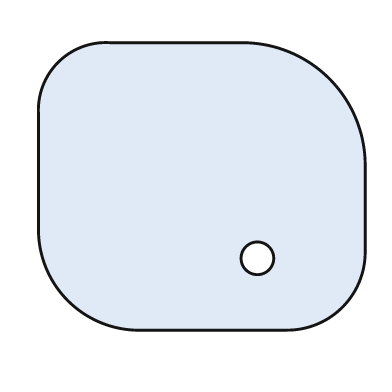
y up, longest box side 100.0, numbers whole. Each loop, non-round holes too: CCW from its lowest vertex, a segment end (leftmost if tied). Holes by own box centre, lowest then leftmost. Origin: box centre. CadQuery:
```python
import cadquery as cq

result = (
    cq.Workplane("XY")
    .moveTo(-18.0, -44.0)
    .lineTo(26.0, -44.0)
    .threePointArc((43.0, -37.0), (50.0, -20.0))
    .lineTo(50.0, 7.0)
    .threePointArc((39.0, 33.0), (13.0, 44.0))
    .lineTo(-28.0, 44.0)
    .threePointArc((-44.0, 38.0), (-50.0, 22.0))
    .lineTo(-50.0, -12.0)
    .threePointArc((-41.0, -35.0), (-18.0, -44.0))
    .close()
    .moveTo(17.0, -22.0)
    .circle(5.0)
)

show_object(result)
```